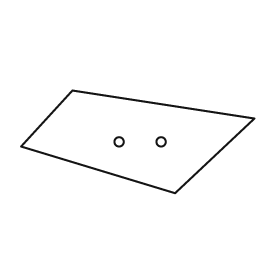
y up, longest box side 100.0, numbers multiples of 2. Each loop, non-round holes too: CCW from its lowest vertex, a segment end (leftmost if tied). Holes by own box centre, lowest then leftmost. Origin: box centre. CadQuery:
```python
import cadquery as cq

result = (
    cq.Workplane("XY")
    .moveTo(16.0, -22.0)
    .lineTo(50.0, 10.0)
    .lineTo(-28.0, 22.0)
    .lineTo(-50.0, -2.0)
    .close()
    .moveTo(-8.0, 0.0)
    .circle(2.0)
    .moveTo(10.0, 0.0)
    .circle(2.0)
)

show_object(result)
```